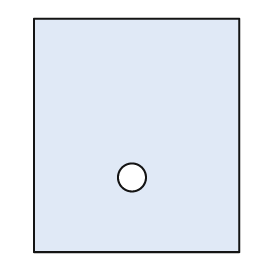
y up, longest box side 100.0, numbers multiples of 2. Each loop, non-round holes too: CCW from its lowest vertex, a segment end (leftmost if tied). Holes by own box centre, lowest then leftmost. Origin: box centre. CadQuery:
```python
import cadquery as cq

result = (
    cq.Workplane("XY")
    .moveTo(-44.0, -50.0)
    .lineTo(44.0, -50.0)
    .lineTo(44.0, 50.0)
    .lineTo(-44.0, 50.0)
    .close()
    .moveTo(-2.0, -18.0)
    .circle(6.0)
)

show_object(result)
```